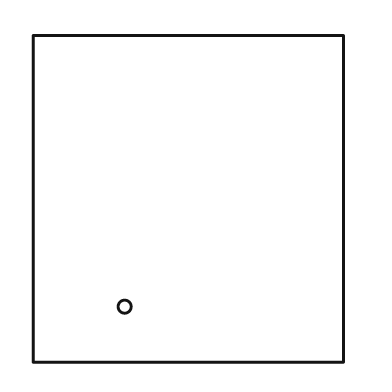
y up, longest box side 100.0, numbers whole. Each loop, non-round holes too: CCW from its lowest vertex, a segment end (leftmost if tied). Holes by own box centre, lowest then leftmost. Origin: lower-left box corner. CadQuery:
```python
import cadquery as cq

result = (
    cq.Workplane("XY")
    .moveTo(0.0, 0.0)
    .lineTo(95.0, 0.0)
    .lineTo(95.0, 100.0)
    .lineTo(0.0, 100.0)
    .close()
    .moveTo(28.0, 17.0)
    .circle(2.0)
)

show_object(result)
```